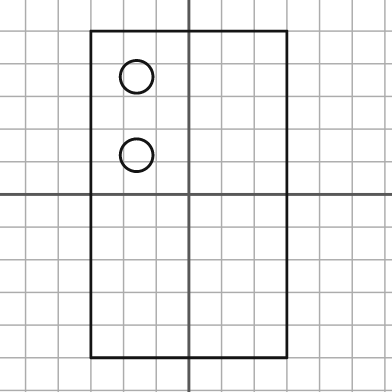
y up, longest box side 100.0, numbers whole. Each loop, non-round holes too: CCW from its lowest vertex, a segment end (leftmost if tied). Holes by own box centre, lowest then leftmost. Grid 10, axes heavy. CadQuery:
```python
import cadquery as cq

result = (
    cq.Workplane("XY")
    .moveTo(-30.0, -50.0)
    .lineTo(30.0, -50.0)
    .lineTo(30.0, 50.0)
    .lineTo(-30.0, 50.0)
    .close()
    .moveTo(-16.0, 12.0)
    .circle(5.0)
    .moveTo(-16.0, 36.0)
    .circle(5.0)
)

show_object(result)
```